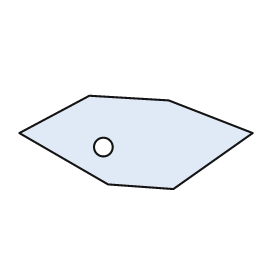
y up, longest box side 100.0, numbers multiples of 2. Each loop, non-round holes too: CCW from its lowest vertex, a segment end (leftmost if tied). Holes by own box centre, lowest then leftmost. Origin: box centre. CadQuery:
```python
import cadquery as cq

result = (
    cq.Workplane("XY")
    .moveTo(16.0, -20.0)
    .lineTo(50.0, 4.0)
    .lineTo(14.0, 18.0)
    .lineTo(-20.0, 20.0)
    .lineTo(-50.0, 4.0)
    .lineTo(-12.0, -18.0)
    .close()
    .moveTo(-14.0, -2.0)
    .circle(4.0)
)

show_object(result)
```